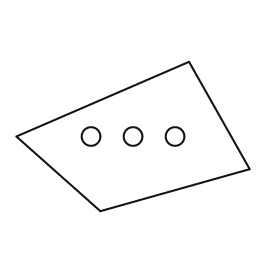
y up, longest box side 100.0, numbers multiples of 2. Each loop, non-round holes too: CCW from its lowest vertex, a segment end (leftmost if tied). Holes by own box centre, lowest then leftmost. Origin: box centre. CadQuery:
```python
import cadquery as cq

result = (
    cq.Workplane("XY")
    .moveTo(-14.0, -32.0)
    .lineTo(50.0, -14.0)
    .lineTo(24.0, 32.0)
    .lineTo(-50.0, 0.0)
    .close()
    .moveTo(-18.0, 0.0)
    .circle(4.0)
    .moveTo(0.0, 0.0)
    .circle(4.0)
    .moveTo(18.0, 0.0)
    .circle(4.0)
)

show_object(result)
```